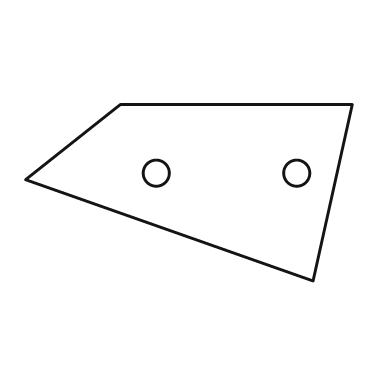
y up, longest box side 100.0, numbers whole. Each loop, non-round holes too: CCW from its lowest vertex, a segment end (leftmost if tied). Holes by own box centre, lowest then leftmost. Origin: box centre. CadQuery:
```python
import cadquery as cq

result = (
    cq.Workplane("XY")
    .moveTo(38.0, -27.0)
    .lineTo(50.0, 27.0)
    .lineTo(-21.0, 27.0)
    .lineTo(-50.0, 4.0)
    .close()
    .moveTo(-10.0, 6.0)
    .circle(4.0)
    .moveTo(33.0, 6.0)
    .circle(4.0)
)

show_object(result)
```